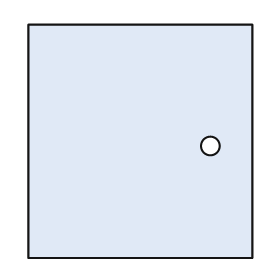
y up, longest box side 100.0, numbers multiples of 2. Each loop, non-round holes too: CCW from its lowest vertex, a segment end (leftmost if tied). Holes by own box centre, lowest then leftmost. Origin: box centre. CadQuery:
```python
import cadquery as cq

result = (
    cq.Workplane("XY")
    .moveTo(-48.0, -50.0)
    .lineTo(48.0, -50.0)
    .lineTo(48.0, 50.0)
    .lineTo(-48.0, 50.0)
    .close()
    .moveTo(30.0, -2.0)
    .circle(4.0)
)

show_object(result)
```